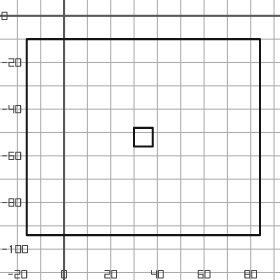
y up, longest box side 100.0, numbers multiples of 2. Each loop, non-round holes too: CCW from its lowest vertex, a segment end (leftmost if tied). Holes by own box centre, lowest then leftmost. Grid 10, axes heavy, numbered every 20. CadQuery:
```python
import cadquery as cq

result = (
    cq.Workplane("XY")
    .moveTo(-16.0, -94.0)
    .lineTo(84.0, -94.0)
    .lineTo(84.0, -10.0)
    .lineTo(-16.0, -10.0)
    .close()
    .moveTo(30.0, -56.0)
    .lineTo(38.0, -56.0)
    .lineTo(38.0, -48.0)
    .lineTo(30.0, -48.0)
    .close()
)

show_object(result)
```